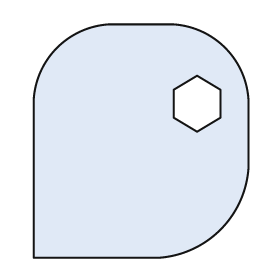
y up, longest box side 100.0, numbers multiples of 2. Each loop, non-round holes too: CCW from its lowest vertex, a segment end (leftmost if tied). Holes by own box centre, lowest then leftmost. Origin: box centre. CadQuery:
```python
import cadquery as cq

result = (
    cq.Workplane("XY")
    .moveTo(-46.0, -50.0)
    .lineTo(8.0, -50.0)
    .threePointArc((34.0, -38.0), (46.0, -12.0))
    .lineTo(46.0, 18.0)
    .threePointArc((36.0, 40.0), (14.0, 50.0))
    .lineTo(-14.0, 50.0)
    .threePointArc((-36.0, 40.0), (-46.0, 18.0))
    .close()
    .moveTo(24.0, 4.0)
    .lineTo(34.0, 10.0)
    .lineTo(34.0, 22.0)
    .lineTo(24.0, 28.0)
    .lineTo(14.0, 22.0)
    .lineTo(14.0, 10.0)
    .close()
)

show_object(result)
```